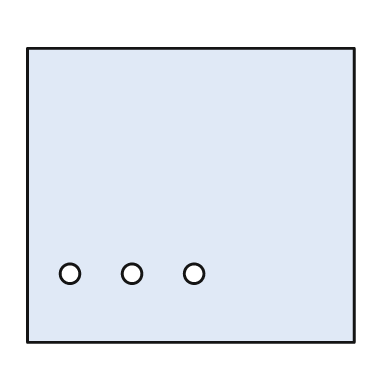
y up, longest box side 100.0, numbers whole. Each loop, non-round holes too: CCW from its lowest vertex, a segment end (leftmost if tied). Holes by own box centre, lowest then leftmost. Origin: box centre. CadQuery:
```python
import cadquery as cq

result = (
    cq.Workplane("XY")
    .moveTo(-50.0, -45.0)
    .lineTo(50.0, -45.0)
    .lineTo(50.0, 45.0)
    .lineTo(-50.0, 45.0)
    .close()
    .moveTo(-37.0, -24.0)
    .circle(3.0)
    .moveTo(-18.0, -24.0)
    .circle(3.0)
    .moveTo(1.0, -24.0)
    .circle(3.0)
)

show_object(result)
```